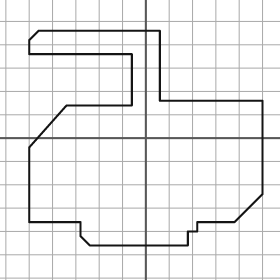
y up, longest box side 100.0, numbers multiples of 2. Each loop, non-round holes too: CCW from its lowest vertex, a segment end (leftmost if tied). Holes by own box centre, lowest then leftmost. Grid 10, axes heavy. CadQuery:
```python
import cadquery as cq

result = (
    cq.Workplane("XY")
    .moveTo(-24.0, -46.0)
    .lineTo(18.0, -46.0)
    .lineTo(18.0, -40.0)
    .lineTo(22.0, -40.0)
    .lineTo(22.0, -36.0)
    .lineTo(38.0, -36.0)
    .lineTo(50.0, -24.0)
    .lineTo(50.0, 16.0)
    .lineTo(6.0, 16.0)
    .lineTo(6.0, 46.0)
    .lineTo(-46.0, 46.0)
    .lineTo(-50.0, 42.0)
    .lineTo(-50.0, 36.0)
    .lineTo(-6.0, 36.0)
    .lineTo(-6.0, 14.0)
    .lineTo(-34.0, 14.0)
    .lineTo(-50.0, -4.0)
    .lineTo(-50.0, -36.0)
    .lineTo(-28.0, -36.0)
    .lineTo(-28.0, -42.0)
    .close()
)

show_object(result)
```